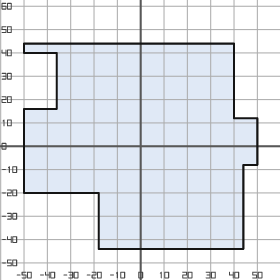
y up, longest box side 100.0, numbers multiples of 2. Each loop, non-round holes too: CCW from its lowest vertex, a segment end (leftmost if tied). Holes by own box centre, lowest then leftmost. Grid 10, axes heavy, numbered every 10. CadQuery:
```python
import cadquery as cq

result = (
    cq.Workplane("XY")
    .moveTo(-18.0, -44.0)
    .lineTo(44.0, -44.0)
    .lineTo(44.0, -8.0)
    .lineTo(50.0, -8.0)
    .lineTo(50.0, 12.0)
    .lineTo(40.0, 12.0)
    .lineTo(40.0, 44.0)
    .lineTo(-50.0, 44.0)
    .lineTo(-50.0, 40.0)
    .lineTo(-36.0, 40.0)
    .lineTo(-36.0, 16.0)
    .lineTo(-50.0, 16.0)
    .lineTo(-50.0, -20.0)
    .lineTo(-18.0, -20.0)
    .close()
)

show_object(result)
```